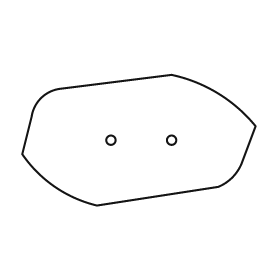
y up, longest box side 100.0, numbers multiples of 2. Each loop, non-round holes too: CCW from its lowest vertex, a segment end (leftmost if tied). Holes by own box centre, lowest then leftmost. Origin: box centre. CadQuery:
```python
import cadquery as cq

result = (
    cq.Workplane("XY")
    .moveTo(-18.0, -28.0)
    .lineTo(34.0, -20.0)
    .threePointArc((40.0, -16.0), (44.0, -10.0))
    .lineTo(50.0, 6.0)
    .threePointArc((34.0, 20.0), (14.0, 28.0))
    .lineTo(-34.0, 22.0)
    .threePointArc((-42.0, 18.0), (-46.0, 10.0))
    .lineTo(-50.0, -6.0)
    .threePointArc((-36.0, -20.0), (-18.0, -28.0))
    .close()
    .moveTo(-12.0, 0.0)
    .circle(2.0)
    .moveTo(14.0, 0.0)
    .circle(2.0)
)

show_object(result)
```